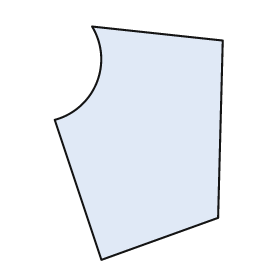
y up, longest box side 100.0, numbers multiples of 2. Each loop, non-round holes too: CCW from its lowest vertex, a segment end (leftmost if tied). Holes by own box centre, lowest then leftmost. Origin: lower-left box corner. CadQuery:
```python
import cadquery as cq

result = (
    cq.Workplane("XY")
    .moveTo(20.0, 0.0)
    .lineTo(70.0, 18.0)
    .lineTo(72.0, 94.0)
    .lineTo(16.0, 100.0)
    .threePointArc((18.0, 76.0), (0.0, 60.0))
    .close()
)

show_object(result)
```